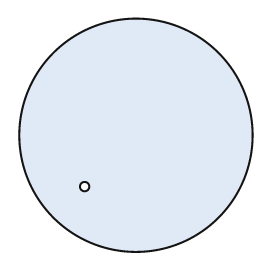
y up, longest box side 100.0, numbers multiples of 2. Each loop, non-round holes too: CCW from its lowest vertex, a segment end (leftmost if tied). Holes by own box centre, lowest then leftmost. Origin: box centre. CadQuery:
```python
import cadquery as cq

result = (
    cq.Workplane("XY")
    .moveTo(0.0, 0.0)
    .circle(50.0)
    .moveTo(-22.0, -22.0)
    .circle(2.0)
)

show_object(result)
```